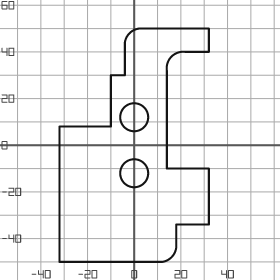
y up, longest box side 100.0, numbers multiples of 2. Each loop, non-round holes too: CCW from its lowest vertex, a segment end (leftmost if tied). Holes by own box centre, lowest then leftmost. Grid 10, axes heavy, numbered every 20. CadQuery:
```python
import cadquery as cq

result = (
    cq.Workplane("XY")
    .moveTo(-32.0, -50.0)
    .lineTo(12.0, -50.0)
    .threePointArc((16.0, -48.0), (18.0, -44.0))
    .lineTo(18.0, -34.0)
    .lineTo(32.0, -34.0)
    .lineTo(32.0, -10.0)
    .lineTo(14.0, -10.0)
    .lineTo(14.0, 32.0)
    .threePointArc((16.0, 38.0), (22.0, 40.0))
    .lineTo(32.0, 40.0)
    .lineTo(32.0, 50.0)
    .lineTo(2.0, 50.0)
    .threePointArc((-2.0, 48.0), (-4.0, 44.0))
    .lineTo(-4.0, 30.0)
    .lineTo(-10.0, 30.0)
    .lineTo(-10.0, 8.0)
    .lineTo(-32.0, 8.0)
    .close()
    .moveTo(0.0, -12.0)
    .circle(6.0)
    .moveTo(0.0, 12.0)
    .circle(6.0)
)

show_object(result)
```